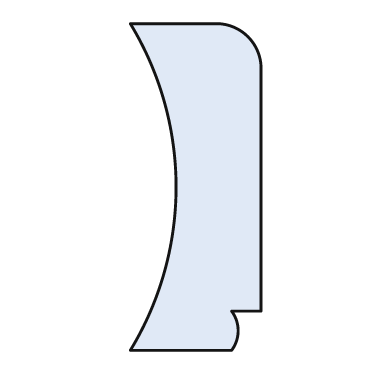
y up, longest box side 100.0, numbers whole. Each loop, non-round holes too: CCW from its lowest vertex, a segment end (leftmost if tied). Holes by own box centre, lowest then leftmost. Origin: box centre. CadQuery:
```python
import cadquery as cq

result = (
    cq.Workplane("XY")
    .moveTo(-20.0, -50.0)
    .lineTo(11.0, -50.0)
    .threePointArc((13.0, -44.0), (11.0, -38.0))
    .lineTo(20.0, -38.0)
    .lineTo(20.0, 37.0)
    .threePointArc((16.0, 46.0), (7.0, 50.0))
    .lineTo(-20.0, 50.0)
    .threePointArc((-6.0, 0.0), (-20.0, -50.0))
    .close()
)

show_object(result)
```